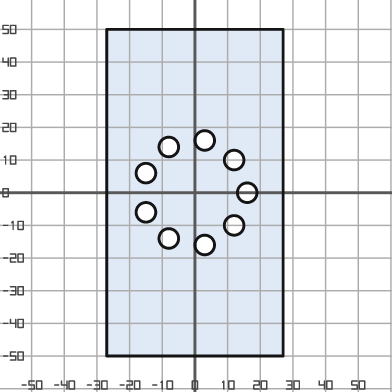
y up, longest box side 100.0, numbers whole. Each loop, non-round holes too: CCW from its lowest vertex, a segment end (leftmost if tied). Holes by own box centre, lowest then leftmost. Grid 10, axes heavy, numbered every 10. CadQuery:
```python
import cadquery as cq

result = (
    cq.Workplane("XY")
    .moveTo(-27.0, -50.0)
    .lineTo(27.0, -50.0)
    .lineTo(27.0, 50.0)
    .lineTo(-27.0, 50.0)
    .close()
    .moveTo(3.0, -16.0)
    .circle(3.0)
    .moveTo(-8.0, -14.0)
    .circle(3.0)
    .moveTo(12.0, -10.0)
    .circle(3.0)
    .moveTo(-15.0, -6.0)
    .circle(3.0)
    .moveTo(16.0, 0.0)
    .circle(3.0)
    .moveTo(-15.0, 6.0)
    .circle(3.0)
    .moveTo(12.0, 10.0)
    .circle(3.0)
    .moveTo(-8.0, 14.0)
    .circle(3.0)
    .moveTo(3.0, 16.0)
    .circle(3.0)
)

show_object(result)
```